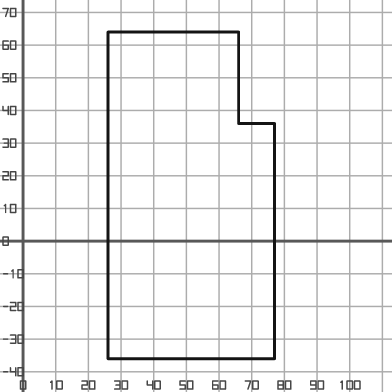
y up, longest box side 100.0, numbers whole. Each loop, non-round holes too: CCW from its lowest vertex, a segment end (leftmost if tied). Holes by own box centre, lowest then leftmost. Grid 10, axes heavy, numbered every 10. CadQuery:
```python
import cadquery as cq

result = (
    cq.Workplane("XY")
    .moveTo(26.0, -36.0)
    .lineTo(77.0, -36.0)
    .lineTo(77.0, 36.0)
    .lineTo(66.0, 36.0)
    .lineTo(66.0, 64.0)
    .lineTo(26.0, 64.0)
    .close()
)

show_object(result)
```